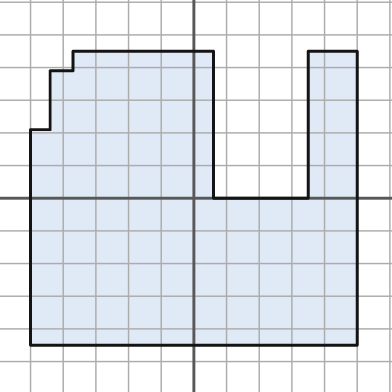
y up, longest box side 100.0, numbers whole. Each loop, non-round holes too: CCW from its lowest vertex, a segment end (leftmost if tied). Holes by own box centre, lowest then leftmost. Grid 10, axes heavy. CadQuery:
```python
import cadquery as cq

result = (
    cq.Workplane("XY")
    .moveTo(-50.0, -45.0)
    .lineTo(50.0, -45.0)
    .lineTo(50.0, 45.0)
    .lineTo(35.0, 45.0)
    .lineTo(35.0, 0.0)
    .lineTo(6.0, 0.0)
    .lineTo(6.0, 45.0)
    .lineTo(-37.0, 45.0)
    .lineTo(-37.0, 39.0)
    .lineTo(-44.0, 39.0)
    .lineTo(-44.0, 21.0)
    .lineTo(-50.0, 21.0)
    .close()
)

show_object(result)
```